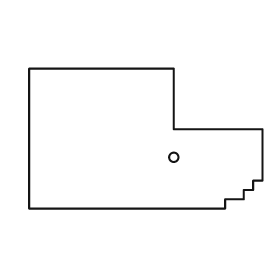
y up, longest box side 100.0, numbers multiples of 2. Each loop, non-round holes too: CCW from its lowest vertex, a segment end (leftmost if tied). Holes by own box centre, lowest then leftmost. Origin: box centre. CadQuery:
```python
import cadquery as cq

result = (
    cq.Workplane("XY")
    .moveTo(-50.0, -30.0)
    .lineTo(34.0, -30.0)
    .lineTo(34.0, -26.0)
    .lineTo(42.0, -26.0)
    .lineTo(42.0, -22.0)
    .lineTo(46.0, -22.0)
    .lineTo(46.0, -18.0)
    .lineTo(50.0, -18.0)
    .lineTo(50.0, 4.0)
    .lineTo(12.0, 4.0)
    .lineTo(12.0, 30.0)
    .lineTo(-50.0, 30.0)
    .close()
    .moveTo(12.0, -8.0)
    .circle(2.0)
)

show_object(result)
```